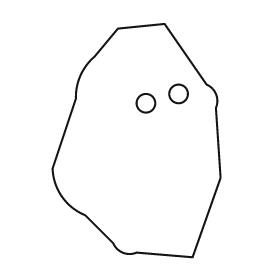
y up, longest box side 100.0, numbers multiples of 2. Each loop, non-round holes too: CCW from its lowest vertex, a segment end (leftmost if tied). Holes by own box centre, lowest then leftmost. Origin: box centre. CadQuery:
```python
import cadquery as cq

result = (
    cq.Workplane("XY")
    .moveTo(24.0, -50.0)
    .lineTo(36.0, -16.0)
    .lineTo(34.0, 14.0)
    .threePointArc((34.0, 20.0), (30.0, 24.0))
    .lineTo(12.0, 50.0)
    .lineTo(-8.0, 48.0)
    .lineTo(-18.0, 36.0)
    .threePointArc((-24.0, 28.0), (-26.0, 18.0))
    .lineTo(-36.0, -12.0)
    .threePointArc((-32.0, -24.0), (-22.0, -32.0))
    .lineTo(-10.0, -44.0)
    .threePointArc((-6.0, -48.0), (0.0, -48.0))
    .close()
    .moveTo(4.0, 16.0)
    .circle(4.0)
    .moveTo(18.0, 20.0)
    .circle(4.0)
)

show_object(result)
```